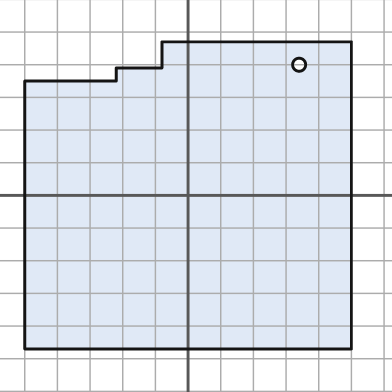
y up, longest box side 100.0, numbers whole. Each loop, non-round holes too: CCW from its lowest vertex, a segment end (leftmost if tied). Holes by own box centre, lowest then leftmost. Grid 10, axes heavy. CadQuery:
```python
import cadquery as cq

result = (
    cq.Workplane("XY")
    .moveTo(-50.0, -47.0)
    .lineTo(50.0, -47.0)
    .lineTo(50.0, 47.0)
    .lineTo(-8.0, 47.0)
    .lineTo(-8.0, 39.0)
    .lineTo(-22.0, 39.0)
    .lineTo(-22.0, 35.0)
    .lineTo(-50.0, 35.0)
    .close()
    .moveTo(34.0, 40.0)
    .circle(2.0)
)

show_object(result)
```